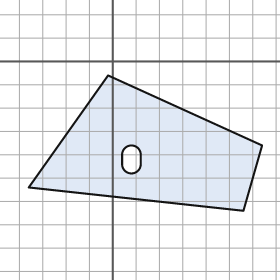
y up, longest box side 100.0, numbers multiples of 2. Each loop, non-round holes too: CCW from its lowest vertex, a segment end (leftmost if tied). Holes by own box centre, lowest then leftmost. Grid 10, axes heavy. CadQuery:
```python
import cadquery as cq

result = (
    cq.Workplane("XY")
    .moveTo(56.0, -64.0)
    .lineTo(64.0, -36.0)
    .lineTo(-2.0, -6.0)
    .lineTo(-36.0, -54.0)
    .close()
    .moveTo(4.0, -44.0)
    .threePointArc((8.0, -48.0), (12.0, -44.0))
    .lineTo(12.0, -40.0)
    .threePointArc((8.0, -36.0), (4.0, -40.0))
    .close()
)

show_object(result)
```